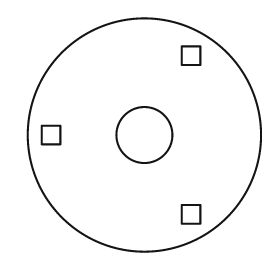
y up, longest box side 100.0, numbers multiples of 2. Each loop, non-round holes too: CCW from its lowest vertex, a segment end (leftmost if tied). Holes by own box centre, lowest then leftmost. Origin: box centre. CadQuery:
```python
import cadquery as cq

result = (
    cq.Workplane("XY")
    .moveTo(0.0, 0.0)
    .circle(50.0)
    .moveTo(16.0, -38.0)
    .lineTo(24.0, -38.0)
    .lineTo(24.0, -30.0)
    .lineTo(16.0, -30.0)
    .close()
    .moveTo(-44.0, -4.0)
    .lineTo(-36.0, -4.0)
    .lineTo(-36.0, 4.0)
    .lineTo(-44.0, 4.0)
    .close()
    .moveTo(0.0, 0.0)
    .circle(12.0)
    .moveTo(16.0, 30.0)
    .lineTo(24.0, 30.0)
    .lineTo(24.0, 38.0)
    .lineTo(16.0, 38.0)
    .close()
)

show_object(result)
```